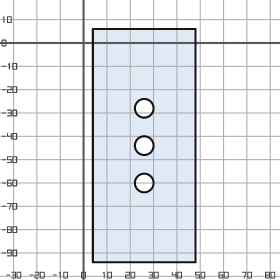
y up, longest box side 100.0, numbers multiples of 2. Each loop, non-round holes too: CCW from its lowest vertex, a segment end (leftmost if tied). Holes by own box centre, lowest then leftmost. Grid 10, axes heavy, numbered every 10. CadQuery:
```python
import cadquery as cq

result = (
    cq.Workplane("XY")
    .moveTo(4.0, -94.0)
    .lineTo(48.0, -94.0)
    .lineTo(48.0, 6.0)
    .lineTo(4.0, 6.0)
    .close()
    .moveTo(26.0, -60.0)
    .circle(4.0)
    .moveTo(26.0, -44.0)
    .circle(4.0)
    .moveTo(26.0, -28.0)
    .circle(4.0)
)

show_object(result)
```